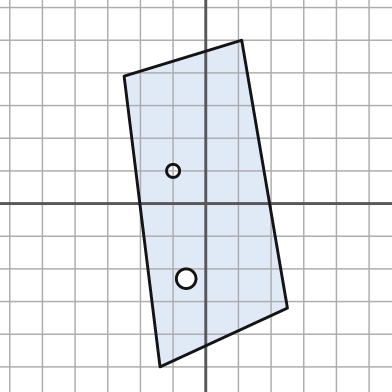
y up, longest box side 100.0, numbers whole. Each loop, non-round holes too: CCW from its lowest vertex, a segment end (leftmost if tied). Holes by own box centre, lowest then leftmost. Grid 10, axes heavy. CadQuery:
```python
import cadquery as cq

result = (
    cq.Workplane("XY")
    .moveTo(-14.0, -50.0)
    .lineTo(25.0, -32.0)
    .lineTo(11.0, 50.0)
    .lineTo(-25.0, 39.0)
    .close()
    .moveTo(-6.0, -23.0)
    .circle(3.0)
    .moveTo(-10.0, 10.0)
    .circle(2.0)
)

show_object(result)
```